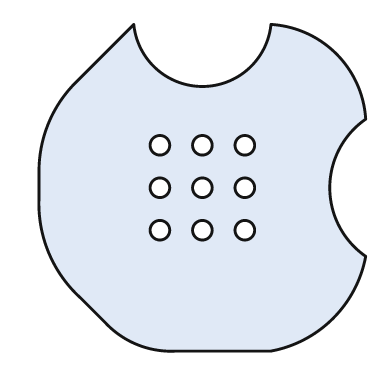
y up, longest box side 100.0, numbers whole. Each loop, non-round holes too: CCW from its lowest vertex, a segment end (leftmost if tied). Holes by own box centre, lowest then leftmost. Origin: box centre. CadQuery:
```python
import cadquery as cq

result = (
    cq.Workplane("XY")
    .moveTo(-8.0, -50.0)
    .lineTo(21.0, -50.0)
    .threePointArc((40.0, -40.0), (50.0, -21.0))
    .threePointArc((39.0, 0.0), (50.0, 21.0))
    .threePointArc((41.0, 41.0), (21.0, 50.0))
    .threePointArc((0.0, 31.0), (-21.0, 50.0))
    .lineTo(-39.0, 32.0)
    .threePointArc((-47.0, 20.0), (-50.0, 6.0))
    .lineTo(-50.0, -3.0)
    .threePointArc((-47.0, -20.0), (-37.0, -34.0))
    .lineTo(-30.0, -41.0)
    .threePointArc((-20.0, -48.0), (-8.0, -50.0))
    .close()
    .moveTo(-13.0, -13.0)
    .circle(3.0)
    .moveTo(0.0, -13.0)
    .circle(3.0)
    .moveTo(13.0, -13.0)
    .circle(3.0)
    .moveTo(-13.0, 0.0)
    .circle(3.0)
    .moveTo(0.0, 0.0)
    .circle(3.0)
    .moveTo(13.0, 0.0)
    .circle(3.0)
    .moveTo(-13.0, 13.0)
    .circle(3.0)
    .moveTo(0.0, 13.0)
    .circle(3.0)
    .moveTo(13.0, 13.0)
    .circle(3.0)
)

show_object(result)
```